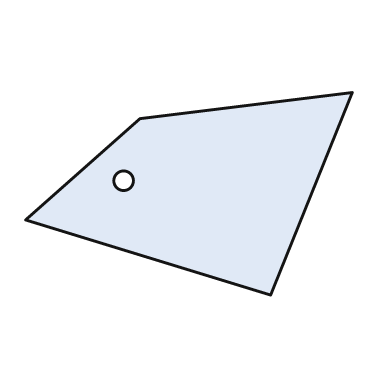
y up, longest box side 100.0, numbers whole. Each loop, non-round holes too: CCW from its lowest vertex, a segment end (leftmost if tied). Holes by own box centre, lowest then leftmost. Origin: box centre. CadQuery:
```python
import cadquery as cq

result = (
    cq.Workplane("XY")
    .moveTo(25.0, -31.0)
    .lineTo(50.0, 31.0)
    .lineTo(-15.0, 23.0)
    .lineTo(-50.0, -8.0)
    .close()
    .moveTo(-20.0, 4.0)
    .circle(3.0)
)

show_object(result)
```